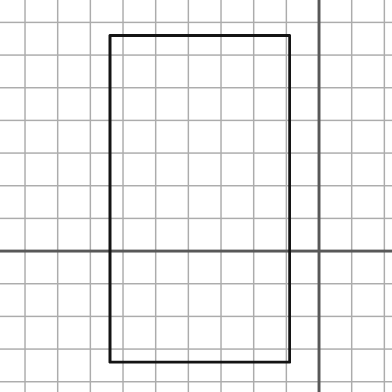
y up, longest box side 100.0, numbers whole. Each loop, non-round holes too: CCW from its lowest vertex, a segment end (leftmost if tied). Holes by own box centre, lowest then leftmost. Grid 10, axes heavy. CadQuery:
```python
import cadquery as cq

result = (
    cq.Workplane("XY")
    .moveTo(-64.0, -34.0)
    .lineTo(-9.0, -34.0)
    .lineTo(-9.0, 66.0)
    .lineTo(-64.0, 66.0)
    .close()
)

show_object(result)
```